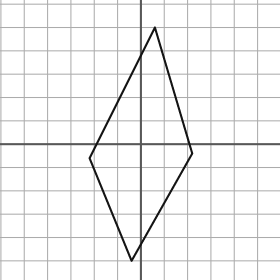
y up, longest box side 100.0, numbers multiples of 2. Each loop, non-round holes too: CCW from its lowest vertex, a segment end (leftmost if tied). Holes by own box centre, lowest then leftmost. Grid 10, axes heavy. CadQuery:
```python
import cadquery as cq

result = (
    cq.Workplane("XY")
    .moveTo(-4.0, -50.0)
    .lineTo(22.0, -4.0)
    .lineTo(6.0, 50.0)
    .lineTo(-22.0, -6.0)
    .close()
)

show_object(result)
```